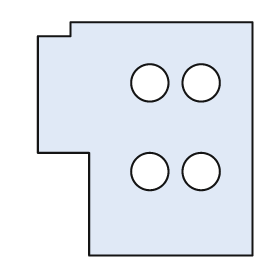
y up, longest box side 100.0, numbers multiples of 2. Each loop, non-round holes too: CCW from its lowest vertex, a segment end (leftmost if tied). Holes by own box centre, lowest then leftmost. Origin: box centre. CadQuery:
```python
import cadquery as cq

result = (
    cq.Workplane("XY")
    .moveTo(-24.0, -50.0)
    .lineTo(46.0, -50.0)
    .lineTo(46.0, 50.0)
    .lineTo(-32.0, 50.0)
    .lineTo(-32.0, 44.0)
    .lineTo(-46.0, 44.0)
    .lineTo(-46.0, -6.0)
    .lineTo(-24.0, -6.0)
    .close()
    .moveTo(2.0, -14.0)
    .circle(8.0)
    .moveTo(24.0, -14.0)
    .circle(8.0)
    .moveTo(2.0, 24.0)
    .circle(8.0)
    .moveTo(24.0, 24.0)
    .circle(8.0)
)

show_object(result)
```